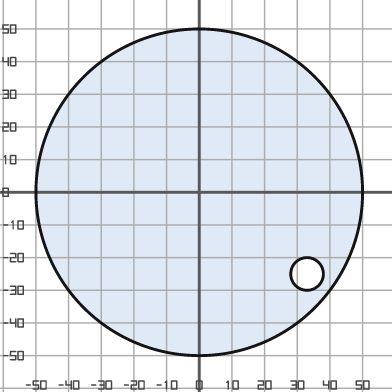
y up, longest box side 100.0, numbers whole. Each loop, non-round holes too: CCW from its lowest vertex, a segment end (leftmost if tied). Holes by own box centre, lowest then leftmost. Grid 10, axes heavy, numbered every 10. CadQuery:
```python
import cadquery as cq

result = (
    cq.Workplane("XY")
    .moveTo(0.0, 0.0)
    .circle(50.0)
    .moveTo(33.0, -25.0)
    .circle(5.0)
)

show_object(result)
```